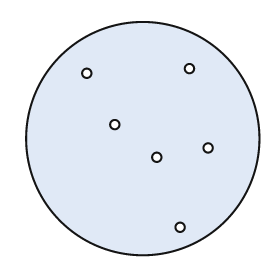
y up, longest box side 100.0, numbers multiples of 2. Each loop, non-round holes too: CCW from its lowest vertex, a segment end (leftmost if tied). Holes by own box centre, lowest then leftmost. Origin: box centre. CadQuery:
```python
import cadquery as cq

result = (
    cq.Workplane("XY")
    .moveTo(0.0, 0.0)
    .circle(50.0)
    .moveTo(16.0, -38.0)
    .circle(2.0)
    .moveTo(6.0, -8.0)
    .circle(2.0)
    .moveTo(28.0, -4.0)
    .circle(2.0)
    .moveTo(-12.0, 6.0)
    .circle(2.0)
    .moveTo(-24.0, 28.0)
    .circle(2.0)
    .moveTo(20.0, 30.0)
    .circle(2.0)
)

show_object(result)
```